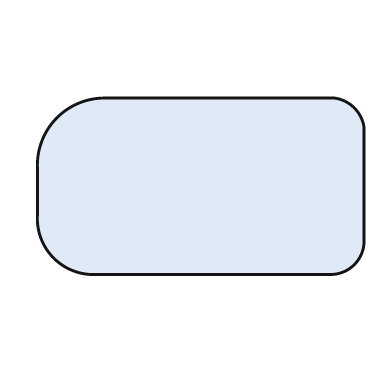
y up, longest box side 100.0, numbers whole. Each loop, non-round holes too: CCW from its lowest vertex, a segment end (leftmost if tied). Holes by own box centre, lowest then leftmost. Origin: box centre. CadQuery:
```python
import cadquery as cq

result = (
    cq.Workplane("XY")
    .moveTo(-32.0, -27.0)
    .lineTo(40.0, -27.0)
    .threePointArc((47.0, -24.0), (50.0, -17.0))
    .lineTo(50.0, 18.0)
    .threePointArc((47.0, 24.0), (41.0, 27.0))
    .lineTo(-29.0, 27.0)
    .threePointArc((-44.0, 21.0), (-50.0, 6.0))
    .lineTo(-50.0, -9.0)
    .threePointArc((-45.0, -22.0), (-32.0, -27.0))
    .close()
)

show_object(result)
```